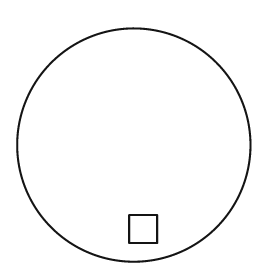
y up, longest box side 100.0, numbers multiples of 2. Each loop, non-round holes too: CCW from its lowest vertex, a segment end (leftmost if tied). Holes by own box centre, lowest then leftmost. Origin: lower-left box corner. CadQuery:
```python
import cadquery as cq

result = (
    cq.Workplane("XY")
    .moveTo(50.0, 50.0)
    .circle(50.0)
    .moveTo(48.0, 8.0)
    .lineTo(60.0, 8.0)
    .lineTo(60.0, 20.0)
    .lineTo(48.0, 20.0)
    .close()
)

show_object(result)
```